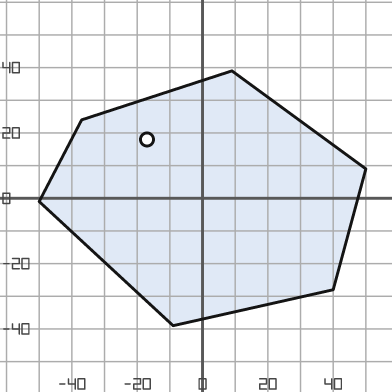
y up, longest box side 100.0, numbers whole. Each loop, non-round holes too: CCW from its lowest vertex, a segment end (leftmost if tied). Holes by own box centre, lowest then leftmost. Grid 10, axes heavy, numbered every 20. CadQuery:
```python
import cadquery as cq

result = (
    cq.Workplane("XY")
    .moveTo(-9.0, -39.0)
    .lineTo(40.0, -28.0)
    .lineTo(50.0, 9.0)
    .lineTo(9.0, 39.0)
    .lineTo(-37.0, 24.0)
    .lineTo(-50.0, -1.0)
    .close()
    .moveTo(-17.0, 18.0)
    .circle(2.0)
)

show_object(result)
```